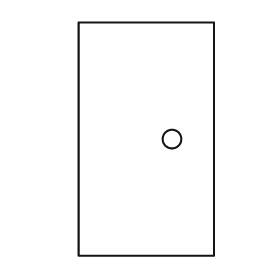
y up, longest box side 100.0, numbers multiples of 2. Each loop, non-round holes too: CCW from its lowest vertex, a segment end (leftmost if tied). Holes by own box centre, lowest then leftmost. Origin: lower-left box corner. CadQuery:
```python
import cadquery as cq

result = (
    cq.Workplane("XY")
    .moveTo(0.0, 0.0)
    .lineTo(58.0, 0.0)
    .lineTo(58.0, 100.0)
    .lineTo(0.0, 100.0)
    .close()
    .moveTo(40.0, 50.0)
    .circle(4.0)
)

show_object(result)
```